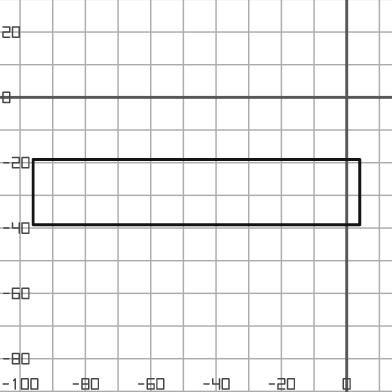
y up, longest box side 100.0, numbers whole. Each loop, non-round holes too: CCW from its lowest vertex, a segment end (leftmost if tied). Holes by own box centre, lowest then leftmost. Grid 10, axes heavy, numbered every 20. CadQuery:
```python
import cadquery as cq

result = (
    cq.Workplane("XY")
    .moveTo(-96.0, -39.0)
    .lineTo(4.0, -39.0)
    .lineTo(4.0, -19.0)
    .lineTo(-96.0, -19.0)
    .close()
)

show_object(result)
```